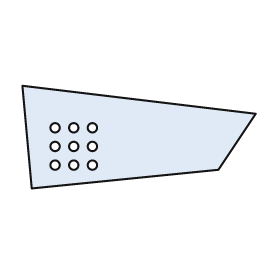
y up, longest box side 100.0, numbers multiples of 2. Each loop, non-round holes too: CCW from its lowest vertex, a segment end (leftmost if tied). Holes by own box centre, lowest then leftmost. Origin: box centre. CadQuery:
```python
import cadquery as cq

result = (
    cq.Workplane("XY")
    .moveTo(-46.0, -22.0)
    .lineTo(34.0, -14.0)
    .lineTo(50.0, 10.0)
    .lineTo(-50.0, 22.0)
    .close()
    .moveTo(-36.0, -12.0)
    .circle(2.0)
    .moveTo(-28.0, -12.0)
    .circle(2.0)
    .moveTo(-20.0, -12.0)
    .circle(2.0)
    .moveTo(-36.0, -4.0)
    .circle(2.0)
    .moveTo(-28.0, -4.0)
    .circle(2.0)
    .moveTo(-20.0, -4.0)
    .circle(2.0)
    .moveTo(-36.0, 4.0)
    .circle(2.0)
    .moveTo(-28.0, 4.0)
    .circle(2.0)
    .moveTo(-20.0, 4.0)
    .circle(2.0)
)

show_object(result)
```